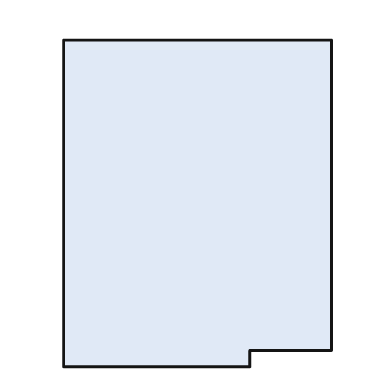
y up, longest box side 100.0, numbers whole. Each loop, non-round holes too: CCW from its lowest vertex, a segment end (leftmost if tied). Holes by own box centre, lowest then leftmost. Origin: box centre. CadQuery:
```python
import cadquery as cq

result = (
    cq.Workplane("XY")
    .moveTo(-41.0, -50.0)
    .lineTo(16.0, -50.0)
    .lineTo(16.0, -45.0)
    .lineTo(41.0, -45.0)
    .lineTo(41.0, 50.0)
    .lineTo(-41.0, 50.0)
    .close()
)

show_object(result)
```